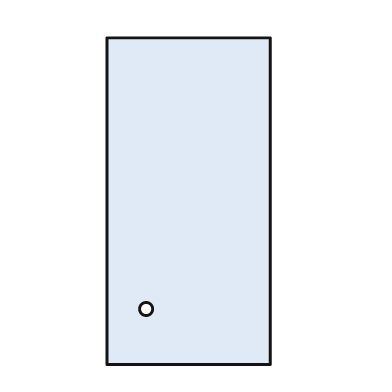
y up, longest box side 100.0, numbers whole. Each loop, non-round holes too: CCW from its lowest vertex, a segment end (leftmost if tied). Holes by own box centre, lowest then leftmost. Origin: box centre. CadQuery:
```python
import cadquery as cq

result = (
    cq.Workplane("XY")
    .moveTo(-25.0, -50.0)
    .lineTo(25.0, -50.0)
    .lineTo(25.0, 50.0)
    .lineTo(-25.0, 50.0)
    .close()
    .moveTo(-13.0, -33.0)
    .circle(2.0)
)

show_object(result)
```